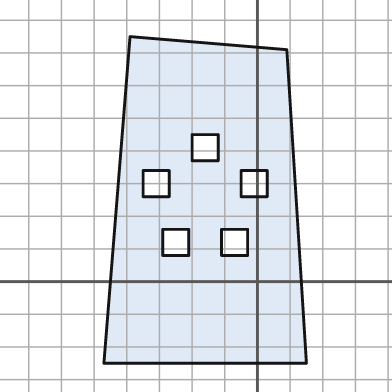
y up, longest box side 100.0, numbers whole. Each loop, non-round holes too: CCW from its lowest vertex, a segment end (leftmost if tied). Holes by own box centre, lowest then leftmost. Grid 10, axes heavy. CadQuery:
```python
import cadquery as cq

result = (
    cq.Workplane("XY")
    .moveTo(-47.0, -25.0)
    .lineTo(15.0, -25.0)
    .lineTo(9.0, 71.0)
    .lineTo(-39.0, 75.0)
    .close()
    .moveTo(-29.0, 8.0)
    .lineTo(-21.0, 8.0)
    .lineTo(-21.0, 16.0)
    .lineTo(-29.0, 16.0)
    .close()
    .moveTo(-11.0, 8.0)
    .lineTo(-3.0, 8.0)
    .lineTo(-3.0, 16.0)
    .lineTo(-11.0, 16.0)
    .close()
    .moveTo(-35.0, 26.0)
    .lineTo(-27.0, 26.0)
    .lineTo(-27.0, 34.0)
    .lineTo(-35.0, 34.0)
    .close()
    .moveTo(-5.0, 26.0)
    .lineTo(3.0, 26.0)
    .lineTo(3.0, 34.0)
    .lineTo(-5.0, 34.0)
    .close()
    .moveTo(-20.0, 37.0)
    .lineTo(-12.0, 37.0)
    .lineTo(-12.0, 45.0)
    .lineTo(-20.0, 45.0)
    .close()
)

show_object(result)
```